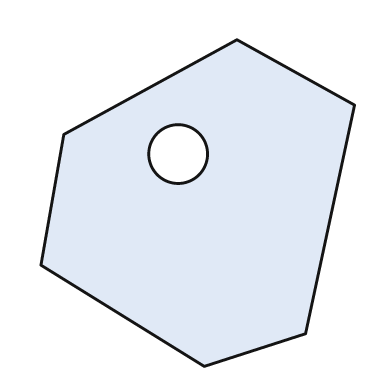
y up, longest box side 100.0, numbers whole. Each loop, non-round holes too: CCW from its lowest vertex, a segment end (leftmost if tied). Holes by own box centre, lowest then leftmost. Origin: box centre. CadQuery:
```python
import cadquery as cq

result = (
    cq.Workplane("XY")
    .moveTo(2.0, -50.0)
    .lineTo(33.0, -40.0)
    .lineTo(48.0, 30.0)
    .lineTo(12.0, 50.0)
    .lineTo(-41.0, 21.0)
    .lineTo(-48.0, -19.0)
    .close()
    .moveTo(-6.0, 15.0)
    .circle(9.0)
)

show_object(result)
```